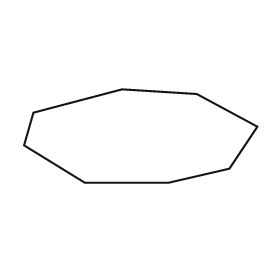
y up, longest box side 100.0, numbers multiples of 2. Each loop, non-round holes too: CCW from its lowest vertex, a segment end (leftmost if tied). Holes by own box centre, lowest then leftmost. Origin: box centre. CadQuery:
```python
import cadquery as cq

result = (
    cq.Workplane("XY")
    .moveTo(-24.0, -20.0)
    .lineTo(12.0, -20.0)
    .lineTo(38.0, -14.0)
    .lineTo(50.0, 4.0)
    .lineTo(24.0, 18.0)
    .lineTo(-8.0, 20.0)
    .lineTo(-46.0, 10.0)
    .lineTo(-50.0, -4.0)
    .close()
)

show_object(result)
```